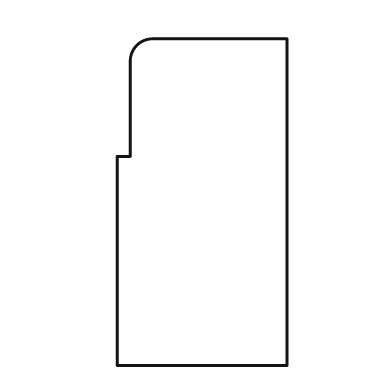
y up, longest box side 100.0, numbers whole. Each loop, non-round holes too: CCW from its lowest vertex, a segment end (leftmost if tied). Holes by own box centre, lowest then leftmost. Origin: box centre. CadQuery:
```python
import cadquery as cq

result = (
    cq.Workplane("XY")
    .moveTo(-26.0, -50.0)
    .lineTo(26.0, -50.0)
    .lineTo(26.0, 50.0)
    .lineTo(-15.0, 50.0)
    .threePointArc((-20.0, 48.0), (-22.0, 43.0))
    .lineTo(-22.0, 14.0)
    .lineTo(-26.0, 14.0)
    .close()
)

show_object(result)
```